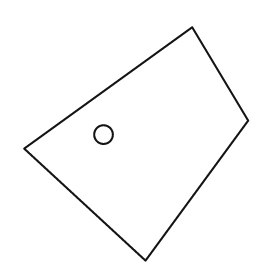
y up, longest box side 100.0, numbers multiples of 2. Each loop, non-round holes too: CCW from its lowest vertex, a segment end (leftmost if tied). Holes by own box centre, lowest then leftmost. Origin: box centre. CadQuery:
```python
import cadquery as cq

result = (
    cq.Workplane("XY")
    .moveTo(4.0, -50.0)
    .lineTo(48.0, 10.0)
    .lineTo(24.0, 50.0)
    .lineTo(-48.0, -2.0)
    .close()
    .moveTo(-14.0, 4.0)
    .circle(4.0)
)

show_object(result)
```